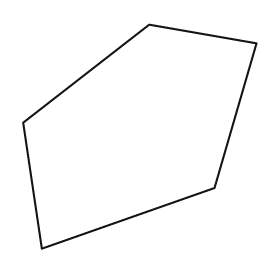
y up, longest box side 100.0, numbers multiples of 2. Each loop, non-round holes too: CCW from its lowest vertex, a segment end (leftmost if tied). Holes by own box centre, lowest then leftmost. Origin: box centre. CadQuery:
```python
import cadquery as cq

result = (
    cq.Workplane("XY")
    .moveTo(-42.0, -48.0)
    .lineTo(32.0, -22.0)
    .lineTo(50.0, 40.0)
    .lineTo(4.0, 48.0)
    .lineTo(-50.0, 6.0)
    .close()
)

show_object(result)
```